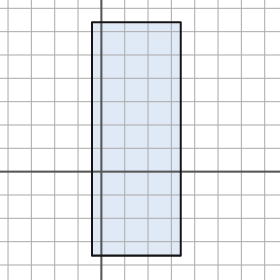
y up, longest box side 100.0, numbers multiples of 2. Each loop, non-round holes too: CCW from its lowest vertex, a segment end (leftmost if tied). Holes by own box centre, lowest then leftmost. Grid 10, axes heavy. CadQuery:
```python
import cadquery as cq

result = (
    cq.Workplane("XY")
    .moveTo(-4.0, -36.0)
    .lineTo(34.0, -36.0)
    .lineTo(34.0, 64.0)
    .lineTo(-4.0, 64.0)
    .close()
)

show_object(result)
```